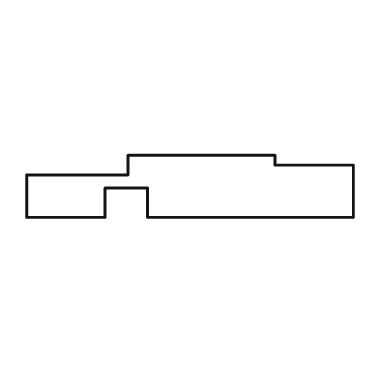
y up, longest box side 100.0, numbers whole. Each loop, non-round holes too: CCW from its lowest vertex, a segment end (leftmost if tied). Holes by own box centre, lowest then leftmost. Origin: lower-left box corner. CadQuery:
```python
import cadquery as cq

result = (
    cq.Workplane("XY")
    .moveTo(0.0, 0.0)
    .lineTo(24.0, 0.0)
    .lineTo(24.0, 9.0)
    .lineTo(37.0, 9.0)
    .lineTo(37.0, 0.0)
    .lineTo(100.0, 0.0)
    .lineTo(100.0, 16.0)
    .lineTo(76.0, 16.0)
    .lineTo(76.0, 19.0)
    .lineTo(31.0, 19.0)
    .lineTo(31.0, 13.0)
    .lineTo(0.0, 13.0)
    .close()
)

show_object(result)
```